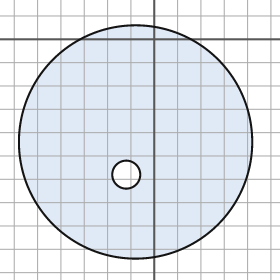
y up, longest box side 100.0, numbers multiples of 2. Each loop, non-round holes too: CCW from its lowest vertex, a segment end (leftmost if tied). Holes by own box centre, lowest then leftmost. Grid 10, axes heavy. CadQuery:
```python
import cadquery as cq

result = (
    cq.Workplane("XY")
    .moveTo(-8.0, -44.0)
    .circle(50.0)
    .moveTo(-12.0, -58.0)
    .circle(6.0)
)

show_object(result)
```